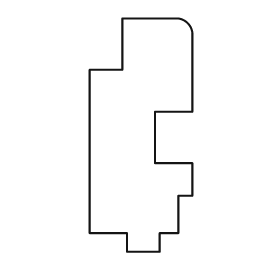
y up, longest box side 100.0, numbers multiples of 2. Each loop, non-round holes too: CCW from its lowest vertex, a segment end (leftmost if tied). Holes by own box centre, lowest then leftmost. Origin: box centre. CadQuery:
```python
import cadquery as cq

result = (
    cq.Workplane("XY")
    .moveTo(-6.0, -50.0)
    .lineTo(8.0, -50.0)
    .lineTo(8.0, -42.0)
    .lineTo(16.0, -42.0)
    .lineTo(16.0, -26.0)
    .lineTo(22.0, -26.0)
    .lineTo(22.0, -12.0)
    .lineTo(6.0, -12.0)
    .lineTo(6.0, 10.0)
    .lineTo(22.0, 10.0)
    .lineTo(22.0, 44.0)
    .threePointArc((20.0, 48.0), (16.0, 50.0))
    .lineTo(-8.0, 50.0)
    .lineTo(-8.0, 28.0)
    .lineTo(-22.0, 28.0)
    .lineTo(-22.0, -42.0)
    .lineTo(-6.0, -42.0)
    .close()
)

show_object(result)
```